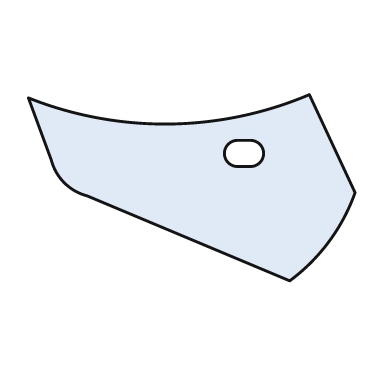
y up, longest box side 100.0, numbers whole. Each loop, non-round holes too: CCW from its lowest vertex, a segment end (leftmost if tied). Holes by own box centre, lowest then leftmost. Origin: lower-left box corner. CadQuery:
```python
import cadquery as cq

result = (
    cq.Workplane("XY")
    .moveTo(80.0, 0.0)
    .threePointArc((92.0, 12.0), (100.0, 27.0))
    .lineTo(86.0, 57.0)
    .threePointArc((43.0, 48.0), (0.0, 56.0))
    .lineTo(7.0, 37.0)
    .threePointArc((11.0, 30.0), (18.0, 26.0))
    .close()
    .moveTo(64.0, 35.0)
    .lineTo(68.0, 35.0)
    .threePointArc((72.0, 39.0), (68.0, 43.0))
    .lineTo(64.0, 43.0)
    .threePointArc((60.0, 39.0), (64.0, 35.0))
    .close()
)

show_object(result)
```